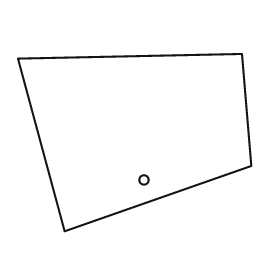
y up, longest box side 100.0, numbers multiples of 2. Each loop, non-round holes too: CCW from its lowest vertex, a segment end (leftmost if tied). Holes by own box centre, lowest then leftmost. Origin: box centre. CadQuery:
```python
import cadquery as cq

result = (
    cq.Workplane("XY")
    .moveTo(-30.0, -38.0)
    .lineTo(50.0, -10.0)
    .lineTo(46.0, 38.0)
    .lineTo(-50.0, 36.0)
    .close()
    .moveTo(4.0, -16.0)
    .circle(2.0)
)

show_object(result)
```